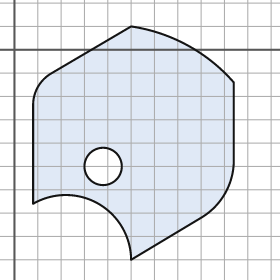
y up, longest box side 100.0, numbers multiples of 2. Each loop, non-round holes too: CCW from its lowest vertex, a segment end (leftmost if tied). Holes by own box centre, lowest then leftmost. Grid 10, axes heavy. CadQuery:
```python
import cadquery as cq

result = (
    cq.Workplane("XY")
    .moveTo(50.0, -90.0)
    .lineTo(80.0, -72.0)
    .threePointArc((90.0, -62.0), (94.0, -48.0))
    .lineTo(94.0, -14.0)
    .threePointArc((74.0, 2.0), (50.0, 10.0))
    .lineTo(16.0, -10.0)
    .threePointArc((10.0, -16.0), (8.0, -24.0))
    .lineTo(8.0, -66.0)
    .threePointArc((36.0, -66.0), (50.0, -90.0))
    .close()
    .moveTo(38.0, -50.0)
    .circle(8.0)
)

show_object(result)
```